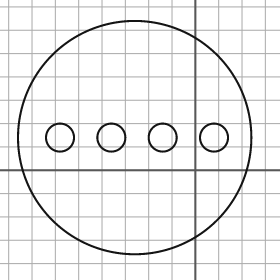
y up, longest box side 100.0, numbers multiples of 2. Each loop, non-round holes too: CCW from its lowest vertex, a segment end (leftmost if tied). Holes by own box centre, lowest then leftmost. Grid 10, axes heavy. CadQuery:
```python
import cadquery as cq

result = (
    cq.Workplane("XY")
    .moveTo(-26.0, 14.0)
    .circle(50.0)
    .moveTo(-58.0, 14.0)
    .circle(6.0)
    .moveTo(-36.0, 14.0)
    .circle(6.0)
    .moveTo(-14.0, 14.0)
    .circle(6.0)
    .moveTo(8.0, 14.0)
    .circle(6.0)
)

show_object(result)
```